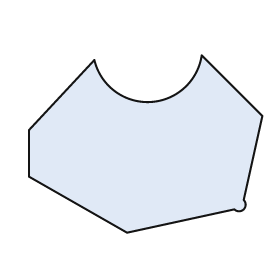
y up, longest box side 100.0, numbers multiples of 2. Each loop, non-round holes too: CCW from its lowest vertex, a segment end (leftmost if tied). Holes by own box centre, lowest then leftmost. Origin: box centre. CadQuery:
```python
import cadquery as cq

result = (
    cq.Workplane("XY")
    .moveTo(-8.0, -38.0)
    .lineTo(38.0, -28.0)
    .threePointArc((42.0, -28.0), (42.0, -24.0))
    .lineTo(50.0, 12.0)
    .lineTo(24.0, 38.0)
    .threePointArc((2.0, 18.0), (-22.0, 36.0))
    .lineTo(-50.0, 6.0)
    .lineTo(-50.0, -14.0)
    .close()
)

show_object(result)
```